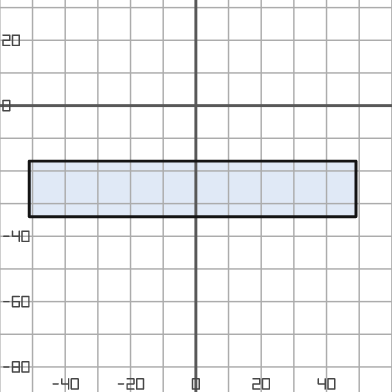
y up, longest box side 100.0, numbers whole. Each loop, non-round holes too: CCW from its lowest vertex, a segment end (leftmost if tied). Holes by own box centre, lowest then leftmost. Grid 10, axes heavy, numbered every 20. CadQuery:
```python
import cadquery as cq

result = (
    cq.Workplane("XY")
    .moveTo(-51.0, -34.0)
    .lineTo(49.0, -34.0)
    .lineTo(49.0, -17.0)
    .lineTo(-51.0, -17.0)
    .close()
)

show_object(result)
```